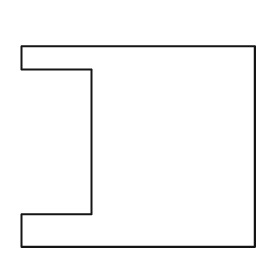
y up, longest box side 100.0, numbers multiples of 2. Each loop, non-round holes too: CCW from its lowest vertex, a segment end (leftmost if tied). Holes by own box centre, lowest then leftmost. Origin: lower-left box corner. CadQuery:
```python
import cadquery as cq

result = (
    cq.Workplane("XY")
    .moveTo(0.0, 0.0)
    .lineTo(100.0, 0.0)
    .lineTo(100.0, 86.0)
    .lineTo(0.0, 86.0)
    .lineTo(0.0, 76.0)
    .lineTo(30.0, 76.0)
    .lineTo(30.0, 14.0)
    .lineTo(0.0, 14.0)
    .close()
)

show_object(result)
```